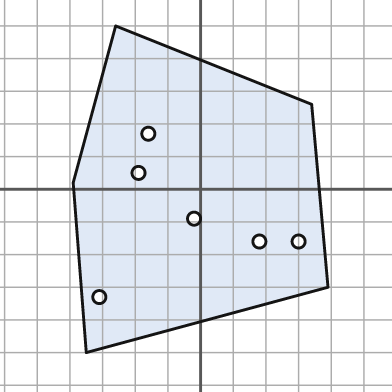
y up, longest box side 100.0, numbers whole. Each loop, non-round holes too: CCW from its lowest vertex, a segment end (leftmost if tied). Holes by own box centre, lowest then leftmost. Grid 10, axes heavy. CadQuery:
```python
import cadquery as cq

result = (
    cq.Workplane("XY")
    .moveTo(-35.0, -50.0)
    .lineTo(39.0, -30.0)
    .lineTo(34.0, 26.0)
    .lineTo(-26.0, 50.0)
    .lineTo(-39.0, 2.0)
    .close()
    .moveTo(-31.0, -33.0)
    .circle(2.0)
    .moveTo(18.0, -16.0)
    .circle(2.0)
    .moveTo(30.0, -16.0)
    .circle(2.0)
    .moveTo(-2.0, -9.0)
    .circle(2.0)
    .moveTo(-19.0, 5.0)
    .circle(2.0)
    .moveTo(-16.0, 17.0)
    .circle(2.0)
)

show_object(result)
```